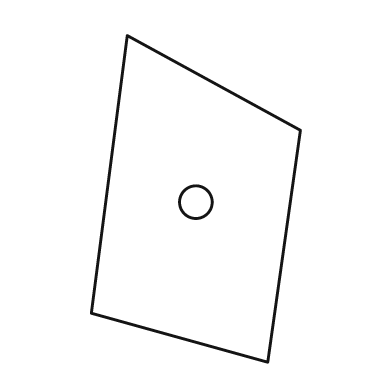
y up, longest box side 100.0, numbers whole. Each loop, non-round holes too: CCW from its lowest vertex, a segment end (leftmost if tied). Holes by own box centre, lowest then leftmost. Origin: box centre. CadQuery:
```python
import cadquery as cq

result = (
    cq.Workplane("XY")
    .moveTo(22.0, -50.0)
    .lineTo(32.0, 21.0)
    .lineTo(-21.0, 50.0)
    .lineTo(-32.0, -35.0)
    .close()
    .moveTo(0.0, -1.0)
    .circle(5.0)
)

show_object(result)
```